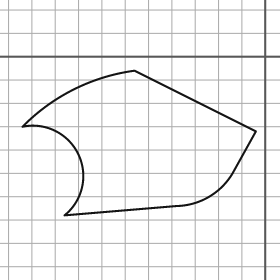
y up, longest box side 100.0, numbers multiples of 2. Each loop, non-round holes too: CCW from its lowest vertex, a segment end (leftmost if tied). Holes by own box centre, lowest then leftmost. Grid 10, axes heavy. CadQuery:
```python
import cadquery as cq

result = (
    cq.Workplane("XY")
    .moveTo(-86.0, -68.0)
    .lineTo(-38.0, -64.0)
    .threePointArc((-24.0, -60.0), (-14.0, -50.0))
    .lineTo(-4.0, -32.0)
    .lineTo(-56.0, -6.0)
    .threePointArc((-82.0, -14.0), (-104.0, -30.0))
    .threePointArc((-80.0, -42.0), (-86.0, -68.0))
    .close()
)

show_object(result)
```